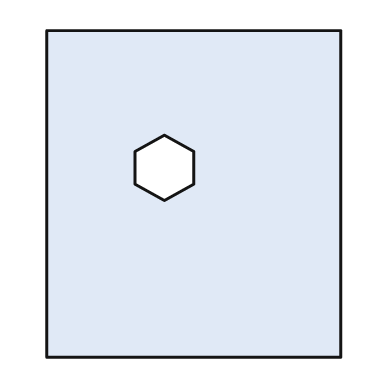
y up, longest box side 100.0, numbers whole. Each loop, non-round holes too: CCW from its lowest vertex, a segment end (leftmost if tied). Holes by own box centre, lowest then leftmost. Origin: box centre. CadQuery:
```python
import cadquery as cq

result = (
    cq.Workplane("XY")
    .moveTo(-45.0, -50.0)
    .lineTo(45.0, -50.0)
    .lineTo(45.0, 50.0)
    .lineTo(-45.0, 50.0)
    .close()
    .moveTo(-9.0, -2.0)
    .lineTo(0.0, 3.0)
    .lineTo(0.0, 13.0)
    .lineTo(-9.0, 18.0)
    .lineTo(-18.0, 13.0)
    .lineTo(-18.0, 3.0)
    .close()
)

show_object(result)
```